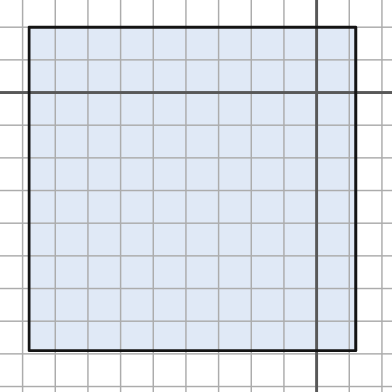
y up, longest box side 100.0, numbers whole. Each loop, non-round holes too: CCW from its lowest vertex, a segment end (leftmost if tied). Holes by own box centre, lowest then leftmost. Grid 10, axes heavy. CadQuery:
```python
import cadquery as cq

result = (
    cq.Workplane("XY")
    .moveTo(-88.0, -79.0)
    .lineTo(12.0, -79.0)
    .lineTo(12.0, 20.0)
    .lineTo(-88.0, 20.0)
    .close()
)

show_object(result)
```